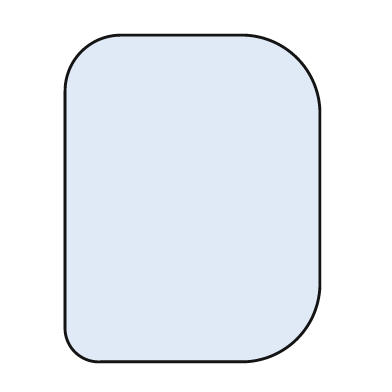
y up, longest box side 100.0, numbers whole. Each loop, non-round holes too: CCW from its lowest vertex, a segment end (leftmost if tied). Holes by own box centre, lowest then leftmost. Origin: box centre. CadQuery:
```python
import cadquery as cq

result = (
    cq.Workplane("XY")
    .moveTo(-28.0, -50.0)
    .lineTo(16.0, -50.0)
    .threePointArc((32.0, -43.0), (39.0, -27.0))
    .lineTo(39.0, 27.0)
    .threePointArc((32.0, 43.0), (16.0, 50.0))
    .lineTo(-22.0, 50.0)
    .threePointArc((-34.0, 45.0), (-39.0, 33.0))
    .lineTo(-39.0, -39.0)
    .threePointArc((-36.0, -47.0), (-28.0, -50.0))
    .close()
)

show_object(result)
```